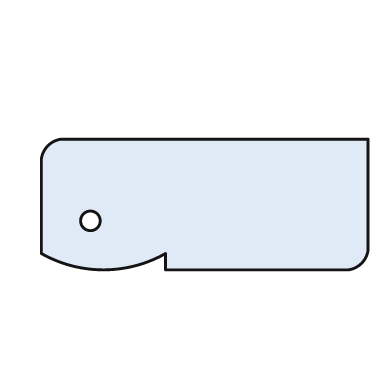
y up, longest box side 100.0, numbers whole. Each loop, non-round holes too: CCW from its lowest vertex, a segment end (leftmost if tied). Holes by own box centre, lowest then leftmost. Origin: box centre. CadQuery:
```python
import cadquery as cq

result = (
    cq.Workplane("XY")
    .moveTo(-12.0, -20.0)
    .lineTo(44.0, -20.0)
    .threePointArc((48.0, -18.0), (50.0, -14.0))
    .lineTo(50.0, 20.0)
    .lineTo(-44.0, 20.0)
    .threePointArc((-48.0, 18.0), (-50.0, 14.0))
    .lineTo(-50.0, -15.0)
    .threePointArc((-31.0, -20.0), (-12.0, -15.0))
    .close()
    .moveTo(-35.0, -5.0)
    .circle(3.0)
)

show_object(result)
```